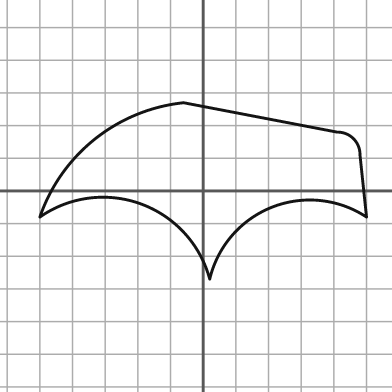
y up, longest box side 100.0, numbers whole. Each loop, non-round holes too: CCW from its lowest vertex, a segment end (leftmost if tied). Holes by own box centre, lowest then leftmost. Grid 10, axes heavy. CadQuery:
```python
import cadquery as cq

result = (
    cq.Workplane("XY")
    .moveTo(2.0, -27.0)
    .threePointArc((21.0, -5.0), (50.0, -8.0))
    .lineTo(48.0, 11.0)
    .threePointArc((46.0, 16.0), (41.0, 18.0))
    .lineTo(-6.0, 27.0)
    .threePointArc((-33.0, 16.0), (-50.0, -8.0))
    .threePointArc((-19.0, -4.0), (2.0, -27.0))
    .close()
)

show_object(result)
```